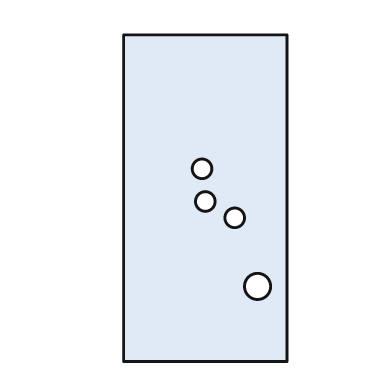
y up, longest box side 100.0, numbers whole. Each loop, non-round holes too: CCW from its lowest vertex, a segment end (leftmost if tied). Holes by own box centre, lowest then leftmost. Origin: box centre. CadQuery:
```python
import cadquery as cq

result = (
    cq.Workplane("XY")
    .moveTo(-25.0, -50.0)
    .lineTo(25.0, -50.0)
    .lineTo(25.0, 50.0)
    .lineTo(-25.0, 50.0)
    .close()
    .moveTo(16.0, -27.0)
    .circle(4.0)
    .moveTo(9.0, -6.0)
    .circle(3.0)
    .moveTo(0.0, -1.0)
    .circle(3.0)
    .moveTo(-1.0, 9.0)
    .circle(3.0)
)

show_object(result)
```